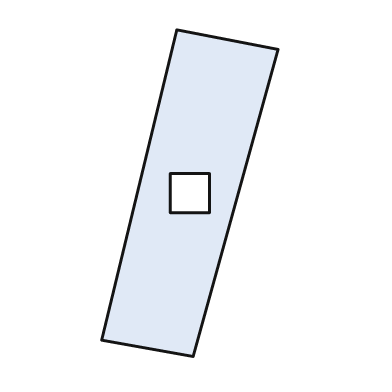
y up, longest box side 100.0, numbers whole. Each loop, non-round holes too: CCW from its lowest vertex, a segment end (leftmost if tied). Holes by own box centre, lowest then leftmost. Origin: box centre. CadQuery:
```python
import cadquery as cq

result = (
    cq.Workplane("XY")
    .moveTo(1.0, -50.0)
    .lineTo(27.0, 44.0)
    .lineTo(-4.0, 50.0)
    .lineTo(-27.0, -45.0)
    .close()
    .moveTo(-6.0, -6.0)
    .lineTo(6.0, -6.0)
    .lineTo(6.0, 6.0)
    .lineTo(-6.0, 6.0)
    .close()
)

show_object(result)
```